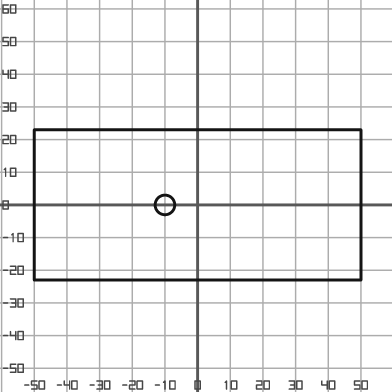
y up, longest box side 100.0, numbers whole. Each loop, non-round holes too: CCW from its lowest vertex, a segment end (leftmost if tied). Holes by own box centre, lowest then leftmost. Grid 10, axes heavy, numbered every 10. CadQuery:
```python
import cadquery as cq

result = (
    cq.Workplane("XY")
    .moveTo(-50.0, -23.0)
    .lineTo(50.0, -23.0)
    .lineTo(50.0, 23.0)
    .lineTo(-50.0, 23.0)
    .close()
    .moveTo(-10.0, 0.0)
    .circle(3.0)
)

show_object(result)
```